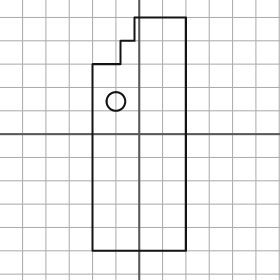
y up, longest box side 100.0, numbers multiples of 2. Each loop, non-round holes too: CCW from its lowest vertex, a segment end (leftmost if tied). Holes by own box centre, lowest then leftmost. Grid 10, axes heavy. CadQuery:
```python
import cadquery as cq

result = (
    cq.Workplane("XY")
    .moveTo(-20.0, -50.0)
    .lineTo(20.0, -50.0)
    .lineTo(20.0, 50.0)
    .lineTo(-2.0, 50.0)
    .lineTo(-2.0, 40.0)
    .lineTo(-8.0, 40.0)
    .lineTo(-8.0, 30.0)
    .lineTo(-20.0, 30.0)
    .close()
    .moveTo(-10.0, 14.0)
    .circle(4.0)
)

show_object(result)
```